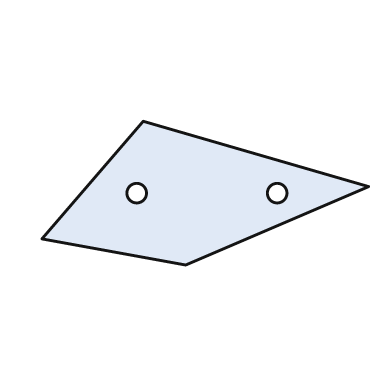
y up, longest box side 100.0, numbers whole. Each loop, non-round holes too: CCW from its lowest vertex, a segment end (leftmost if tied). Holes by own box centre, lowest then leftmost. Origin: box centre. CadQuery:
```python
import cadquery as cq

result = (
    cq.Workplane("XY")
    .moveTo(-6.0, -22.0)
    .lineTo(50.0, 2.0)
    .lineTo(-19.0, 22.0)
    .lineTo(-50.0, -14.0)
    .close()
    .moveTo(-21.0, 0.0)
    .circle(3.0)
    .moveTo(22.0, 0.0)
    .circle(3.0)
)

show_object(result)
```